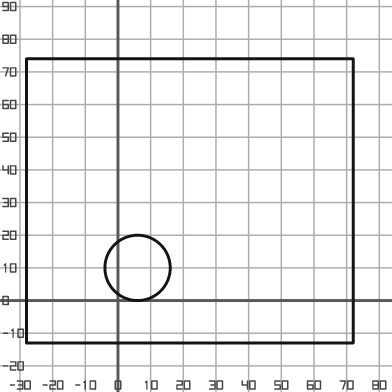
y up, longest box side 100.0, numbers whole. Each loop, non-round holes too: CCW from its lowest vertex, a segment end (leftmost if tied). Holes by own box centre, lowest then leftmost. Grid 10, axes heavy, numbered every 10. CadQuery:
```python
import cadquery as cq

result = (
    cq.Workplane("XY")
    .moveTo(-28.0, -13.0)
    .lineTo(72.0, -13.0)
    .lineTo(72.0, 74.0)
    .lineTo(-28.0, 74.0)
    .close()
    .moveTo(6.0, 10.0)
    .circle(10.0)
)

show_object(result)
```